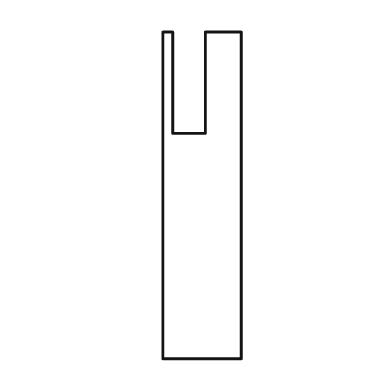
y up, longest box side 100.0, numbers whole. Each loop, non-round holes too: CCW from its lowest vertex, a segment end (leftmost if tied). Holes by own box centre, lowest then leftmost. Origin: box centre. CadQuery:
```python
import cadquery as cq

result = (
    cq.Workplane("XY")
    .moveTo(-12.0, -50.0)
    .lineTo(12.0, -50.0)
    .lineTo(12.0, 50.0)
    .lineTo(1.0, 50.0)
    .lineTo(1.0, 19.0)
    .lineTo(-9.0, 19.0)
    .lineTo(-9.0, 50.0)
    .lineTo(-12.0, 50.0)
    .close()
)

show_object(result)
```